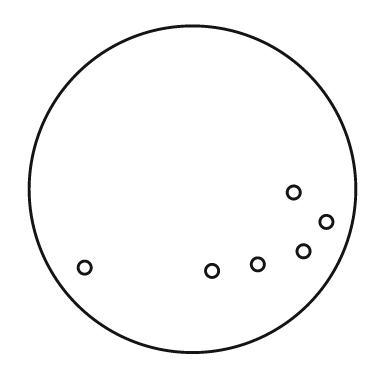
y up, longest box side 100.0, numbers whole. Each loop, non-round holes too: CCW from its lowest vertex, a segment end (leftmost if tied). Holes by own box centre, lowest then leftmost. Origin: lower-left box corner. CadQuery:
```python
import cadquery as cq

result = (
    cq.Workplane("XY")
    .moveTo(50.0, 50.0)
    .circle(50.0)
    .moveTo(56.0, 25.0)
    .circle(2.0)
    .moveTo(17.0, 26.0)
    .circle(2.0)
    .moveTo(70.0, 27.0)
    .circle(2.0)
    .moveTo(84.0, 31.0)
    .circle(2.0)
    .moveTo(91.0, 40.0)
    .circle(2.0)
    .moveTo(81.0, 49.0)
    .circle(2.0)
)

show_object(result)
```